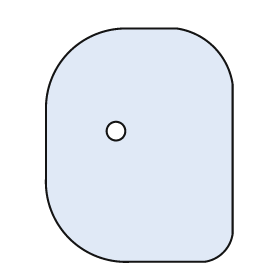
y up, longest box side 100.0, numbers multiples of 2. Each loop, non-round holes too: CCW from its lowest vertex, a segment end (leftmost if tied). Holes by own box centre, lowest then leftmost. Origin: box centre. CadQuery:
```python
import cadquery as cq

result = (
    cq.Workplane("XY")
    .moveTo(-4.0, -50.0)
    .lineTo(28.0, -50.0)
    .threePointArc((36.0, -46.0), (40.0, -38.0))
    .lineTo(40.0, 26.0)
    .threePointArc((32.0, 42.0), (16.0, 50.0))
    .lineTo(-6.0, 50.0)
    .threePointArc((-30.0, 40.0), (-40.0, 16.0))
    .lineTo(-40.0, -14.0)
    .threePointArc((-30.0, -40.0), (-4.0, -50.0))
    .close()
    .moveTo(-10.0, 6.0)
    .circle(4.0)
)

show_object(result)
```